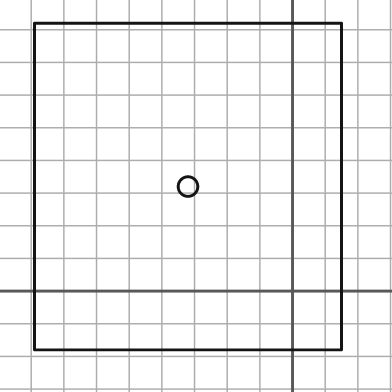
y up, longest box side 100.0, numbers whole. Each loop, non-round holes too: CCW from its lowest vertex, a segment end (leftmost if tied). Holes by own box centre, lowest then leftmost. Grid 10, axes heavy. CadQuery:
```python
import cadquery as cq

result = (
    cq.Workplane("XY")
    .moveTo(-79.0, -18.0)
    .lineTo(15.0, -18.0)
    .lineTo(15.0, 82.0)
    .lineTo(-79.0, 82.0)
    .close()
    .moveTo(-32.0, 32.0)
    .circle(3.0)
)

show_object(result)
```